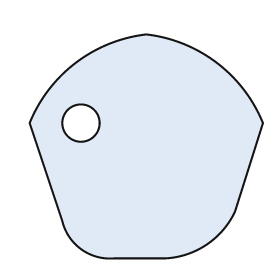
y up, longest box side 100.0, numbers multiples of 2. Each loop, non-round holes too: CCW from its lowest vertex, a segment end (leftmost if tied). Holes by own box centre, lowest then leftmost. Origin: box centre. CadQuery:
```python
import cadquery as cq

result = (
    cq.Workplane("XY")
    .moveTo(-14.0, -48.0)
    .lineTo(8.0, -48.0)
    .threePointArc((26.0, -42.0), (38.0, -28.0))
    .lineTo(50.0, 10.0)
    .threePointArc((30.0, 36.0), (0.0, 48.0))
    .threePointArc((-30.0, 36.0), (-50.0, 10.0))
    .lineTo(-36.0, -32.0)
    .threePointArc((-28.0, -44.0), (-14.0, -48.0))
    .close()
    .moveTo(-28.0, 10.0)
    .circle(8.0)
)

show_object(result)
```